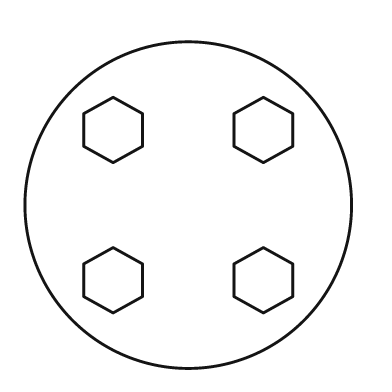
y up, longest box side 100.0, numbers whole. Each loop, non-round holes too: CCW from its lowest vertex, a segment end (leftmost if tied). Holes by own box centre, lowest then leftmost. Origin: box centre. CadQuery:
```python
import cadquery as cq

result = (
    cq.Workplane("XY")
    .moveTo(0.0, 0.0)
    .circle(50.0)
    .moveTo(-23.0, -33.0)
    .lineTo(-14.0, -28.0)
    .lineTo(-14.0, -18.0)
    .lineTo(-23.0, -13.0)
    .lineTo(-32.0, -18.0)
    .lineTo(-32.0, -28.0)
    .close()
    .moveTo(23.0, -33.0)
    .lineTo(32.0, -28.0)
    .lineTo(32.0, -18.0)
    .lineTo(23.0, -13.0)
    .lineTo(14.0, -18.0)
    .lineTo(14.0, -28.0)
    .close()
    .moveTo(-23.0, 13.0)
    .lineTo(-14.0, 18.0)
    .lineTo(-14.0, 28.0)
    .lineTo(-23.0, 33.0)
    .lineTo(-32.0, 28.0)
    .lineTo(-32.0, 18.0)
    .close()
    .moveTo(23.0, 13.0)
    .lineTo(32.0, 18.0)
    .lineTo(32.0, 28.0)
    .lineTo(23.0, 33.0)
    .lineTo(14.0, 28.0)
    .lineTo(14.0, 18.0)
    .close()
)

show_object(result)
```